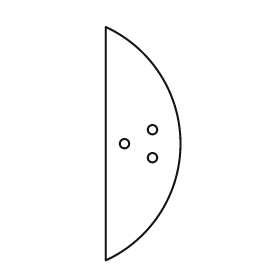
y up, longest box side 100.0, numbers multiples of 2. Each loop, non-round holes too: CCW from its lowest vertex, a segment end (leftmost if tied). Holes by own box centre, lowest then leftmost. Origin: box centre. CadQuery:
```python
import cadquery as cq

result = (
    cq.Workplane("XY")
    .moveTo(-16.0, -50.0)
    .threePointArc((16.0, 0.0), (-16.0, 50.0))
    .close()
    .moveTo(4.0, -6.0)
    .circle(2.0)
    .moveTo(-8.0, 0.0)
    .circle(2.0)
    .moveTo(4.0, 6.0)
    .circle(2.0)
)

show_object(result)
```